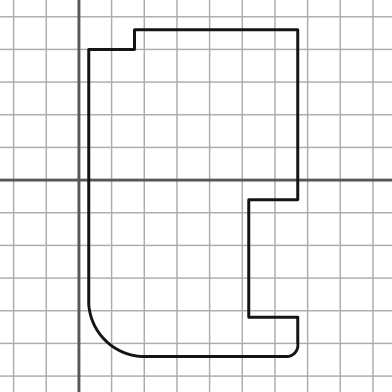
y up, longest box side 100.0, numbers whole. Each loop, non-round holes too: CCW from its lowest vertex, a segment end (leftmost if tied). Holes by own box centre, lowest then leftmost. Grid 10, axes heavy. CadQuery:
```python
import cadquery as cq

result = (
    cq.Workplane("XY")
    .moveTo(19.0, -54.0)
    .lineTo(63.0, -54.0)
    .threePointArc((66.0, -53.0), (67.0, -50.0))
    .lineTo(67.0, -42.0)
    .lineTo(52.0, -42.0)
    .lineTo(52.0, -6.0)
    .lineTo(67.0, -6.0)
    .lineTo(67.0, 46.0)
    .lineTo(17.0, 46.0)
    .lineTo(17.0, 40.0)
    .lineTo(3.0, 40.0)
    .lineTo(3.0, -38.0)
    .threePointArc((8.0, -49.0), (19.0, -54.0))
    .close()
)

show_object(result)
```